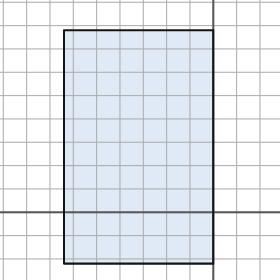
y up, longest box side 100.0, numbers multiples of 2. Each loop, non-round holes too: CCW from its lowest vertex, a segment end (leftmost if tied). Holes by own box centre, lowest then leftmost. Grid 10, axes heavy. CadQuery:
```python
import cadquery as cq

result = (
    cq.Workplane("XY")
    .moveTo(-64.0, -22.0)
    .lineTo(0.0, -22.0)
    .lineTo(0.0, 78.0)
    .lineTo(-64.0, 78.0)
    .close()
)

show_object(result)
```